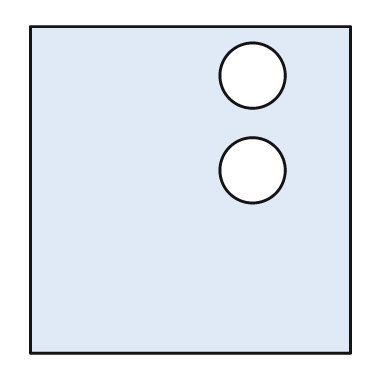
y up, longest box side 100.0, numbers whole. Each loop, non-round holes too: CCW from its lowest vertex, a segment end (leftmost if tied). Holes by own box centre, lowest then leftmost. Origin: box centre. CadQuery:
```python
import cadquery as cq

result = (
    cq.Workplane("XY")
    .moveTo(-49.0, -50.0)
    .lineTo(49.0, -50.0)
    .lineTo(49.0, 50.0)
    .lineTo(-49.0, 50.0)
    .close()
    .moveTo(19.0, 6.0)
    .circle(10.0)
    .moveTo(19.0, 35.0)
    .circle(10.0)
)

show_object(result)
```